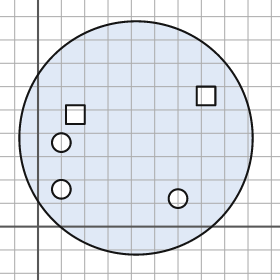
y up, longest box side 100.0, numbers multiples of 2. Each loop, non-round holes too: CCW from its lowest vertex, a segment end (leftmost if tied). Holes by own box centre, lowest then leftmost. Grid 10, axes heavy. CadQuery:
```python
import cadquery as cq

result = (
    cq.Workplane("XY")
    .moveTo(42.0, 38.0)
    .circle(50.0)
    .moveTo(60.0, 12.0)
    .circle(4.0)
    .moveTo(10.0, 16.0)
    .circle(4.0)
    .moveTo(10.0, 36.0)
    .circle(4.0)
    .moveTo(12.0, 44.0)
    .lineTo(20.0, 44.0)
    .lineTo(20.0, 52.0)
    .lineTo(12.0, 52.0)
    .close()
    .moveTo(68.0, 52.0)
    .lineTo(76.0, 52.0)
    .lineTo(76.0, 60.0)
    .lineTo(68.0, 60.0)
    .close()
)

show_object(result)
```